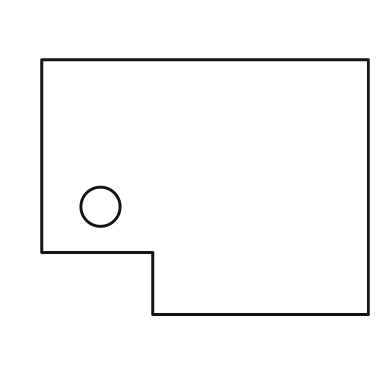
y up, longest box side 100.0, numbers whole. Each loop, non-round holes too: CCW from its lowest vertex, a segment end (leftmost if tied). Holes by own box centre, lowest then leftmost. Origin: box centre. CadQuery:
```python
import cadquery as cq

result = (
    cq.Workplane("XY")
    .moveTo(-16.0, -39.0)
    .lineTo(50.0, -39.0)
    .lineTo(50.0, 39.0)
    .lineTo(-50.0, 39.0)
    .lineTo(-50.0, -20.0)
    .lineTo(-16.0, -20.0)
    .close()
    .moveTo(-32.0, -6.0)
    .circle(6.0)
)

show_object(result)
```